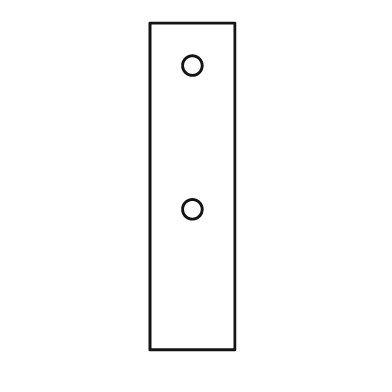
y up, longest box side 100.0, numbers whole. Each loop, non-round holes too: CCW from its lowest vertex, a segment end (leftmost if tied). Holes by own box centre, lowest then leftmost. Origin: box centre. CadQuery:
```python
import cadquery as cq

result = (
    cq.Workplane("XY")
    .moveTo(-13.0, -50.0)
    .lineTo(13.0, -50.0)
    .lineTo(13.0, 50.0)
    .lineTo(-13.0, 50.0)
    .close()
    .moveTo(0.0, -7.0)
    .circle(3.0)
    .moveTo(0.0, 37.0)
    .circle(3.0)
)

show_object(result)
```